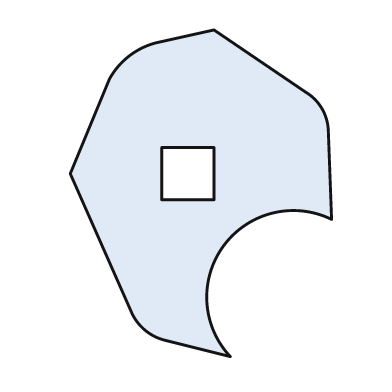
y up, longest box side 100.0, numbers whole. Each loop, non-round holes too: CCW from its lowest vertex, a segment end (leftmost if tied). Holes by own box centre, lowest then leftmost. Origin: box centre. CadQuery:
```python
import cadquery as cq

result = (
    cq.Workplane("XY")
    .moveTo(9.0, -50.0)
    .threePointArc((7.0, -16.0), (40.0, -8.0))
    .lineTo(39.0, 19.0)
    .threePointArc((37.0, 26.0), (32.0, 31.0))
    .lineTo(4.0, 50.0)
    .lineTo(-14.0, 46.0)
    .threePointArc((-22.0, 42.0), (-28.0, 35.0))
    .lineTo(-40.0, 6.0)
    .lineTo(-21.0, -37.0)
    .threePointArc((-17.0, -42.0), (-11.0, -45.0))
    .close()
    .moveTo(-12.0, -2.0)
    .lineTo(4.0, -2.0)
    .lineTo(4.0, 14.0)
    .lineTo(-12.0, 14.0)
    .close()
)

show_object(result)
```